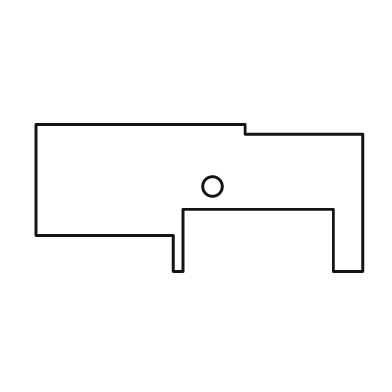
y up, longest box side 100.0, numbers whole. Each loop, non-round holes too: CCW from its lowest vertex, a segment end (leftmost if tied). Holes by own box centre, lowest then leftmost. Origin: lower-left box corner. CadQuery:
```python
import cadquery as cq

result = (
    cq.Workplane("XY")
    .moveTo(42.0, 0.0)
    .lineTo(45.0, 0.0)
    .lineTo(45.0, 19.0)
    .lineTo(91.0, 19.0)
    .lineTo(91.0, 0.0)
    .lineTo(100.0, 0.0)
    .lineTo(100.0, 42.0)
    .lineTo(64.0, 42.0)
    .lineTo(64.0, 45.0)
    .lineTo(0.0, 45.0)
    .lineTo(0.0, 11.0)
    .lineTo(42.0, 11.0)
    .close()
    .moveTo(54.0, 26.0)
    .circle(3.0)
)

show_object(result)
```